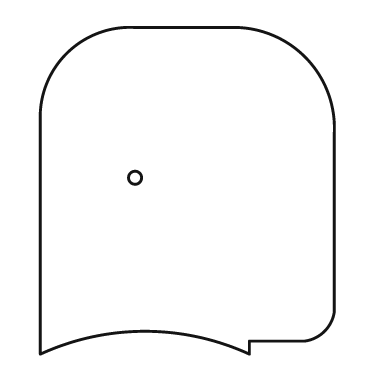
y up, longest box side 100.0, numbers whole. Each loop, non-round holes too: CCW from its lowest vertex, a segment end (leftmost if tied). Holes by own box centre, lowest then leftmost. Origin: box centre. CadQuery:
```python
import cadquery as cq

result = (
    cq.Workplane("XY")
    .moveTo(-45.0, -50.0)
    .threePointArc((-13.0, -43.0), (19.0, -50.0))
    .lineTo(19.0, -46.0)
    .lineTo(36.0, -46.0)
    .threePointArc((42.0, -43.0), (45.0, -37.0))
    .lineTo(45.0, 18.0)
    .threePointArc((36.0, 41.0), (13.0, 50.0))
    .lineTo(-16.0, 50.0)
    .threePointArc((-37.0, 42.0), (-45.0, 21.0))
    .close()
    .moveTo(-16.0, 4.0)
    .circle(2.0)
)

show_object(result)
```